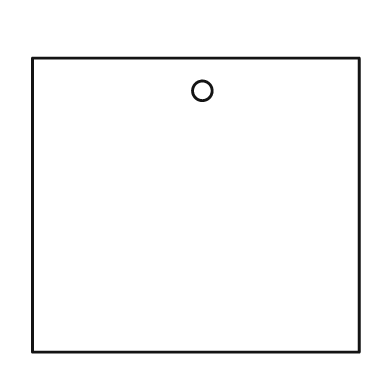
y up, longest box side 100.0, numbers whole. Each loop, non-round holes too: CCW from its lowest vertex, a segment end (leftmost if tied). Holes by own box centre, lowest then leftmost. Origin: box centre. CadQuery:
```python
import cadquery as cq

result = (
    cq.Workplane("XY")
    .moveTo(-50.0, -45.0)
    .lineTo(50.0, -45.0)
    .lineTo(50.0, 45.0)
    .lineTo(-50.0, 45.0)
    .close()
    .moveTo(2.0, 35.0)
    .circle(3.0)
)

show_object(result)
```